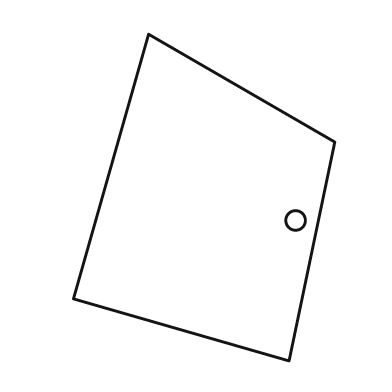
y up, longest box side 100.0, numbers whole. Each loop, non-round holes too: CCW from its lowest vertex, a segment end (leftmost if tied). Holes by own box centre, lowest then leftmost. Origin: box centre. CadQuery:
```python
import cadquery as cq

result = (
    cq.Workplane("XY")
    .moveTo(26.0, -50.0)
    .lineTo(40.0, 17.0)
    .lineTo(-17.0, 50.0)
    .lineTo(-40.0, -31.0)
    .close()
    .moveTo(28.0, -7.0)
    .circle(3.0)
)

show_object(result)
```